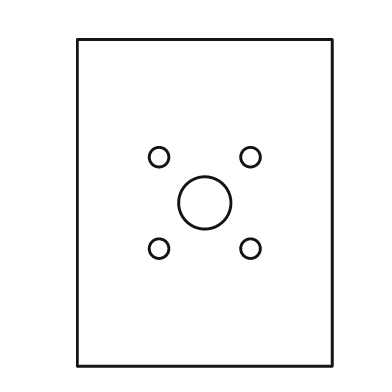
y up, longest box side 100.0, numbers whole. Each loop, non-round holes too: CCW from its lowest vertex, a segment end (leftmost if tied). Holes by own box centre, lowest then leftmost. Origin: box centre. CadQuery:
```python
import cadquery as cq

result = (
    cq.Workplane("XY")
    .moveTo(-39.0, -50.0)
    .lineTo(39.0, -50.0)
    .lineTo(39.0, 50.0)
    .lineTo(-39.0, 50.0)
    .close()
    .moveTo(-14.0, -14.0)
    .circle(3.0)
    .moveTo(14.0, -14.0)
    .circle(3.0)
    .moveTo(0.0, 0.0)
    .circle(8.0)
    .moveTo(-14.0, 14.0)
    .circle(3.0)
    .moveTo(14.0, 14.0)
    .circle(3.0)
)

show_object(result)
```